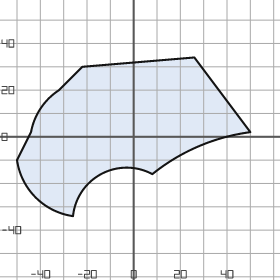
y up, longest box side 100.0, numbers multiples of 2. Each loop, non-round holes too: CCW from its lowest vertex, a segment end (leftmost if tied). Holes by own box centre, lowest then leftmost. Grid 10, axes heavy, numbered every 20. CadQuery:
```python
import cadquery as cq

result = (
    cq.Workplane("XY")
    .moveTo(-26.0, -34.0)
    .threePointArc((-14.0, -16.0), (8.0, -16.0))
    .threePointArc((28.0, -4.0), (50.0, 2.0))
    .lineTo(26.0, 34.0)
    .lineTo(-22.0, 30.0)
    .lineTo(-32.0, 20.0)
    .threePointArc((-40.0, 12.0), (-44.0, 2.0))
    .lineTo(-50.0, -10.0)
    .threePointArc((-42.0, -26.0), (-26.0, -34.0))
    .close()
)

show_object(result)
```